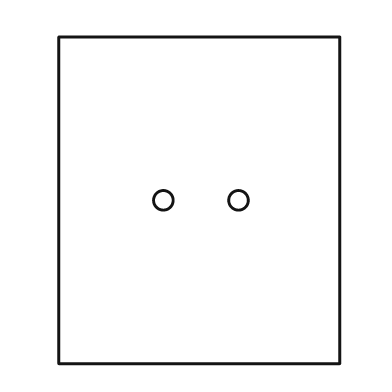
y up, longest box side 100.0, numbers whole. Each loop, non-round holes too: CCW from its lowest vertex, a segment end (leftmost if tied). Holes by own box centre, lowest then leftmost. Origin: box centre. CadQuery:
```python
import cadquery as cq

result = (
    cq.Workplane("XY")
    .moveTo(-43.0, -50.0)
    .lineTo(43.0, -50.0)
    .lineTo(43.0, 50.0)
    .lineTo(-43.0, 50.0)
    .close()
    .moveTo(-11.0, 0.0)
    .circle(3.0)
    .moveTo(12.0, 0.0)
    .circle(3.0)
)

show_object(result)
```